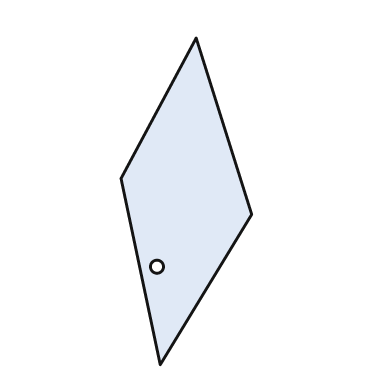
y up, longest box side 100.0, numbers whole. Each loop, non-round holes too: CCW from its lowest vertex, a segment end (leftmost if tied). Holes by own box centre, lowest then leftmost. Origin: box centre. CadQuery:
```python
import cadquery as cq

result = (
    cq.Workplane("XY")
    .moveTo(-8.0, -50.0)
    .lineTo(20.0, -4.0)
    .lineTo(3.0, 50.0)
    .lineTo(-20.0, 7.0)
    .close()
    .moveTo(-9.0, -20.0)
    .circle(2.0)
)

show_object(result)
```